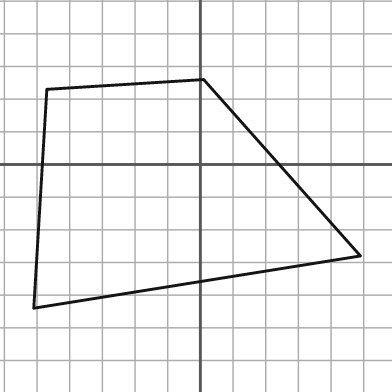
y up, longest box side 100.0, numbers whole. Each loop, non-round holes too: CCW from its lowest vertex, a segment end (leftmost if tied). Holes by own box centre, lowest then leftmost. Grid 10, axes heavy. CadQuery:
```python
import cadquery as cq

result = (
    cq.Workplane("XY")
    .moveTo(-51.0, -44.0)
    .lineTo(49.0, -28.0)
    .lineTo(1.0, 26.0)
    .lineTo(-47.0, 23.0)
    .close()
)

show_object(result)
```